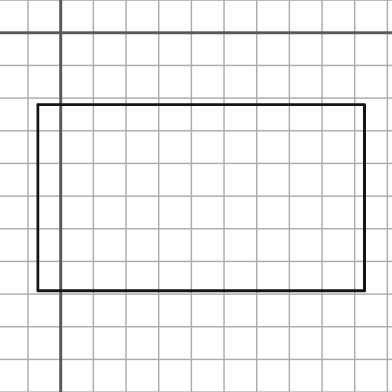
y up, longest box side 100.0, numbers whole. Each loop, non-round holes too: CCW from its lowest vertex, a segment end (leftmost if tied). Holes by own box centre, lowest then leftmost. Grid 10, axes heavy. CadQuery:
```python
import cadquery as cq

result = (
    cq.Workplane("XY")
    .moveTo(-7.0, -79.0)
    .lineTo(93.0, -79.0)
    .lineTo(93.0, -22.0)
    .lineTo(-7.0, -22.0)
    .close()
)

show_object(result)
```